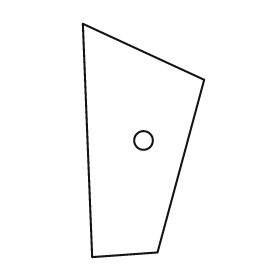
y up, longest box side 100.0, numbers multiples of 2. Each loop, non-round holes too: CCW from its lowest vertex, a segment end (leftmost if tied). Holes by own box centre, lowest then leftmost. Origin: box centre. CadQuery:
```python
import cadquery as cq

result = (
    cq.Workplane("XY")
    .moveTo(-22.0, -50.0)
    .lineTo(6.0, -48.0)
    .lineTo(26.0, 26.0)
    .lineTo(-26.0, 50.0)
    .close()
    .moveTo(0.0, 0.0)
    .circle(4.0)
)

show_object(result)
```